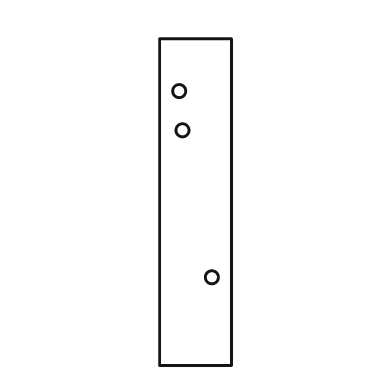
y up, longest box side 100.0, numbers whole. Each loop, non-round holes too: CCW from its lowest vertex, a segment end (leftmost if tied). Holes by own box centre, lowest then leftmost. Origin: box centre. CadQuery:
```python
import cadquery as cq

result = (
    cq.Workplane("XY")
    .moveTo(-11.0, -50.0)
    .lineTo(11.0, -50.0)
    .lineTo(11.0, 50.0)
    .lineTo(-11.0, 50.0)
    .close()
    .moveTo(5.0, -23.0)
    .circle(2.0)
    .moveTo(-4.0, 22.0)
    .circle(2.0)
    .moveTo(-5.0, 34.0)
    .circle(2.0)
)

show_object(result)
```